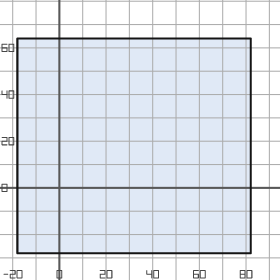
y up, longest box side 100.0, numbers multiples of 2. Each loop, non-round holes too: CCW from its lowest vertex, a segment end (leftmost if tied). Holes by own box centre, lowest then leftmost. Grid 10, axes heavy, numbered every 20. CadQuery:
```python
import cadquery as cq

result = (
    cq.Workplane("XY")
    .moveTo(-18.0, -28.0)
    .lineTo(82.0, -28.0)
    .lineTo(82.0, 64.0)
    .lineTo(-18.0, 64.0)
    .close()
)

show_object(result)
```